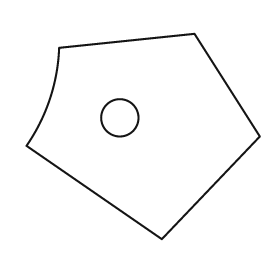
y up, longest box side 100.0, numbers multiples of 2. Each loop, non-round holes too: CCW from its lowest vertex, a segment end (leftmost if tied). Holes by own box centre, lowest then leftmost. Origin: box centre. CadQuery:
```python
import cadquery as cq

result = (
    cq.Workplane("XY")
    .moveTo(8.0, -44.0)
    .lineTo(50.0, 0.0)
    .lineTo(22.0, 44.0)
    .lineTo(-36.0, 38.0)
    .threePointArc((-40.0, 16.0), (-50.0, -4.0))
    .close()
    .moveTo(-10.0, 8.0)
    .circle(8.0)
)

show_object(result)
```